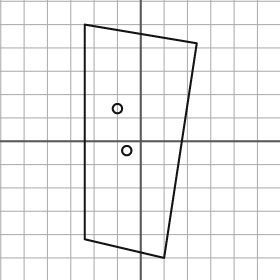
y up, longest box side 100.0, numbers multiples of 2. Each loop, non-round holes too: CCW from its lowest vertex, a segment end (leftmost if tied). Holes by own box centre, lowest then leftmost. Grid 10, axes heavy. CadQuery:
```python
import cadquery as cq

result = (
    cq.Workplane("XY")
    .moveTo(10.0, -50.0)
    .lineTo(24.0, 42.0)
    .lineTo(-24.0, 50.0)
    .lineTo(-24.0, -42.0)
    .close()
    .moveTo(-6.0, -4.0)
    .circle(2.0)
    .moveTo(-10.0, 14.0)
    .circle(2.0)
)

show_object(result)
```